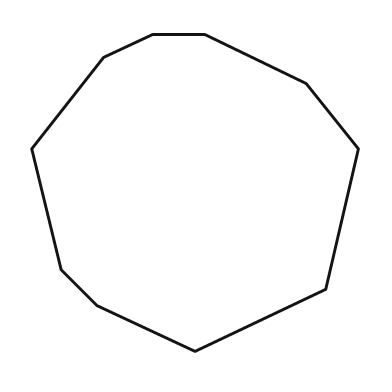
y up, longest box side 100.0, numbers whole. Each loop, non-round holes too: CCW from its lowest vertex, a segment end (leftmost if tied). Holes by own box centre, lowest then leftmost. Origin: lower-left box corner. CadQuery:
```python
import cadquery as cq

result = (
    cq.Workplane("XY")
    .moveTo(50.0, 0.0)
    .lineTo(90.0, 19.0)
    .lineTo(100.0, 62.0)
    .lineTo(84.0, 82.0)
    .lineTo(53.0, 97.0)
    .lineTo(37.0, 97.0)
    .lineTo(22.0, 90.0)
    .lineTo(0.0, 62.0)
    .lineTo(9.0, 25.0)
    .lineTo(20.0, 14.0)
    .close()
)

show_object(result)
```